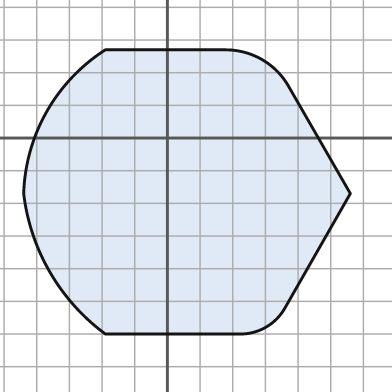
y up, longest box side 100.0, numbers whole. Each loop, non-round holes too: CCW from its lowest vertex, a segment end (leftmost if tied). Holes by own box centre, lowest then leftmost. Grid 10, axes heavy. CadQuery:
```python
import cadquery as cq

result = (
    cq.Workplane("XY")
    .moveTo(-19.0, -60.0)
    .lineTo(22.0, -60.0)
    .threePointArc((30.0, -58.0), (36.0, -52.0))
    .lineTo(56.0, -17.0)
    .lineTo(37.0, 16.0)
    .threePointArc((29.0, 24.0), (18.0, 27.0))
    .lineTo(-19.0, 27.0)
    .threePointArc((-37.0, 8.0), (-44.0, -17.0))
    .threePointArc((-36.0, -41.0), (-19.0, -60.0))
    .close()
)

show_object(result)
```